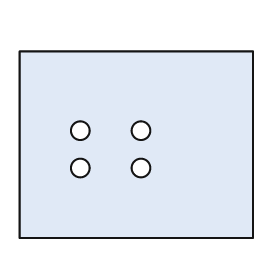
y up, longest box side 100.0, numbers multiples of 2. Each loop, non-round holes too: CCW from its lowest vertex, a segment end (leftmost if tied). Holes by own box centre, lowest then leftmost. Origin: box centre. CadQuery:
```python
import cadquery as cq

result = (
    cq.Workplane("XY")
    .moveTo(-50.0, -40.0)
    .lineTo(50.0, -40.0)
    .lineTo(50.0, 40.0)
    .lineTo(-50.0, 40.0)
    .close()
    .moveTo(-24.0, -10.0)
    .circle(4.0)
    .moveTo(2.0, -10.0)
    .circle(4.0)
    .moveTo(-24.0, 6.0)
    .circle(4.0)
    .moveTo(2.0, 6.0)
    .circle(4.0)
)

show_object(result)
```